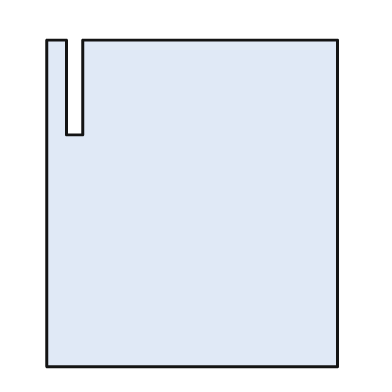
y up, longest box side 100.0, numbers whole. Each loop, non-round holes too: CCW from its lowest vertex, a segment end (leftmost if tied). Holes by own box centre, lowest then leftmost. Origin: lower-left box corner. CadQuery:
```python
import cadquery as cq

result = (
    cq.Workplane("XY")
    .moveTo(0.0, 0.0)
    .lineTo(89.0, 0.0)
    .lineTo(89.0, 100.0)
    .lineTo(11.0, 100.0)
    .lineTo(11.0, 71.0)
    .lineTo(6.0, 71.0)
    .lineTo(6.0, 100.0)
    .lineTo(0.0, 100.0)
    .close()
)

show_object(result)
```